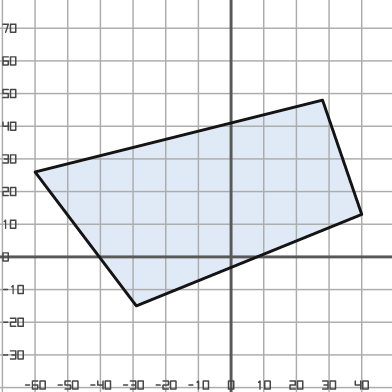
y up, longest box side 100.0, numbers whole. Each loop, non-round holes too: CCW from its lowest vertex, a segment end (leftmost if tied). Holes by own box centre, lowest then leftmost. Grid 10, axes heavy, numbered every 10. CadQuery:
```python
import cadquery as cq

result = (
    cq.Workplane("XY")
    .moveTo(-29.0, -15.0)
    .lineTo(40.0, 13.0)
    .lineTo(28.0, 48.0)
    .lineTo(-60.0, 26.0)
    .close()
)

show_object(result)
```